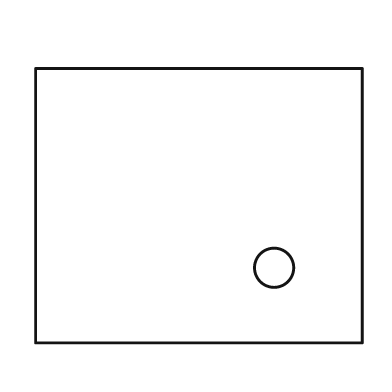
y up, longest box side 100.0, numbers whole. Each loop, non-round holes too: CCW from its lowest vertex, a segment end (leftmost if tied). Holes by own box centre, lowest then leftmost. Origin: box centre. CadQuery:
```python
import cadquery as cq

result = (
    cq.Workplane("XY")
    .moveTo(-50.0, -42.0)
    .lineTo(50.0, -42.0)
    .lineTo(50.0, 42.0)
    .lineTo(-50.0, 42.0)
    .close()
    .moveTo(23.0, -19.0)
    .circle(6.0)
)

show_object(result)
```